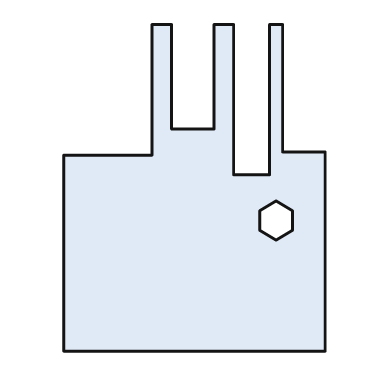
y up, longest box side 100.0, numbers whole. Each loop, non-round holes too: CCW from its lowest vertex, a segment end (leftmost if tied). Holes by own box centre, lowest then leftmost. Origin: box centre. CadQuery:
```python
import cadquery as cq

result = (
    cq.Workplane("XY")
    .moveTo(-40.0, -50.0)
    .lineTo(40.0, -50.0)
    .lineTo(40.0, 11.0)
    .lineTo(27.0, 11.0)
    .lineTo(27.0, 50.0)
    .lineTo(23.0, 50.0)
    .lineTo(23.0, 4.0)
    .lineTo(12.0, 4.0)
    .lineTo(12.0, 50.0)
    .lineTo(6.0, 50.0)
    .lineTo(6.0, 18.0)
    .lineTo(-7.0, 18.0)
    .lineTo(-7.0, 50.0)
    .lineTo(-13.0, 50.0)
    .lineTo(-13.0, 10.0)
    .lineTo(-40.0, 10.0)
    .close()
    .moveTo(25.0, -16.0)
    .lineTo(30.0, -13.0)
    .lineTo(30.0, -7.0)
    .lineTo(25.0, -4.0)
    .lineTo(20.0, -7.0)
    .lineTo(20.0, -13.0)
    .close()
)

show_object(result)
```